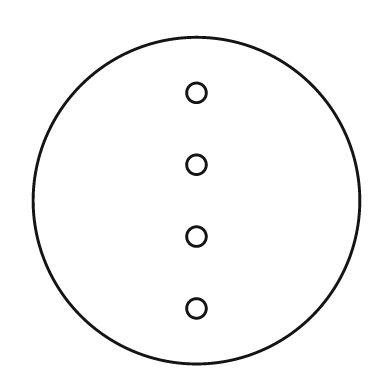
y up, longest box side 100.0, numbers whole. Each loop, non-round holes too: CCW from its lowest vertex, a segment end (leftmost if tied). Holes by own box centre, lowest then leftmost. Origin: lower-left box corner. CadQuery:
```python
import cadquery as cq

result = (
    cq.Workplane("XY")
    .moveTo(50.0, 50.0)
    .circle(50.0)
    .moveTo(50.0, 17.0)
    .circle(3.0)
    .moveTo(50.0, 39.0)
    .circle(3.0)
    .moveTo(50.0, 61.0)
    .circle(3.0)
    .moveTo(50.0, 83.0)
    .circle(3.0)
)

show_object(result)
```